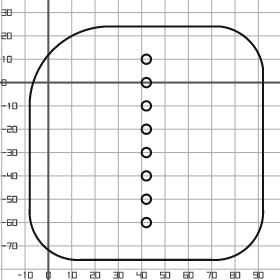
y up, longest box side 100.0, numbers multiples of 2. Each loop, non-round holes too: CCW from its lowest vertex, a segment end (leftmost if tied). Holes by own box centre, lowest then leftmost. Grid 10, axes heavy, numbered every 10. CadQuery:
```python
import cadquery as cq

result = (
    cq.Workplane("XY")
    .moveTo(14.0, -76.0)
    .lineTo(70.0, -76.0)
    .threePointArc((86.0, -70.0), (92.0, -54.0))
    .lineTo(92.0, 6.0)
    .threePointArc((86.0, 18.0), (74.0, 24.0))
    .lineTo(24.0, 24.0)
    .threePointArc((2.0, 14.0), (-8.0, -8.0))
    .lineTo(-8.0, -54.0)
    .threePointArc((-2.0, -70.0), (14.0, -76.0))
    .close()
    .moveTo(42.0, -60.0)
    .circle(2.0)
    .moveTo(42.0, -50.0)
    .circle(2.0)
    .moveTo(42.0, -40.0)
    .circle(2.0)
    .moveTo(42.0, -30.0)
    .circle(2.0)
    .moveTo(42.0, -20.0)
    .circle(2.0)
    .moveTo(42.0, -10.0)
    .circle(2.0)
    .moveTo(42.0, 0.0)
    .circle(2.0)
    .moveTo(42.0, 10.0)
    .circle(2.0)
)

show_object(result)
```